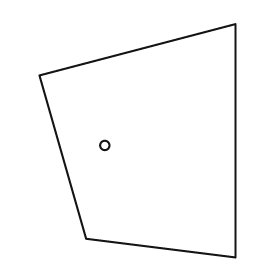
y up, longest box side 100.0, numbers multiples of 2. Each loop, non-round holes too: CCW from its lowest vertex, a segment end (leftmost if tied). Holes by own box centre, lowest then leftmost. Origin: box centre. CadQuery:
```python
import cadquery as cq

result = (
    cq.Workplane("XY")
    .moveTo(42.0, -50.0)
    .lineTo(42.0, 50.0)
    .lineTo(-42.0, 28.0)
    .lineTo(-22.0, -42.0)
    .close()
    .moveTo(-14.0, -2.0)
    .circle(2.0)
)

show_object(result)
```